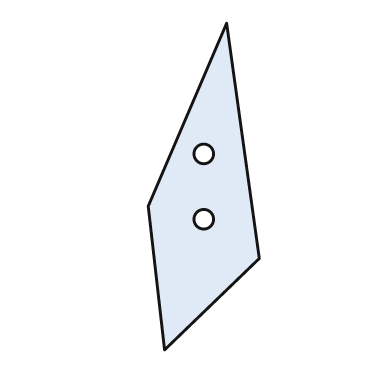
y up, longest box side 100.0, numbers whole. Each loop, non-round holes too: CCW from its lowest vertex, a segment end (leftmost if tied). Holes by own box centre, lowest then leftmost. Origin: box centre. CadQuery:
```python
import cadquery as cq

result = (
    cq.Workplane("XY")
    .moveTo(-12.0, -50.0)
    .lineTo(17.0, -22.0)
    .lineTo(7.0, 50.0)
    .lineTo(-17.0, -6.0)
    .close()
    .moveTo(0.0, -10.0)
    .circle(3.0)
    .moveTo(0.0, 10.0)
    .circle(3.0)
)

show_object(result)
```